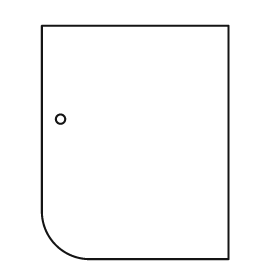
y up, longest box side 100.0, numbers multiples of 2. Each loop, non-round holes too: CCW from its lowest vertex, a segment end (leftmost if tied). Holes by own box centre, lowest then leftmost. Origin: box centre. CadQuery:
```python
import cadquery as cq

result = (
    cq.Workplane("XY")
    .moveTo(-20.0, -50.0)
    .lineTo(40.0, -50.0)
    .lineTo(40.0, 50.0)
    .lineTo(-40.0, 50.0)
    .lineTo(-40.0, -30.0)
    .threePointArc((-34.0, -44.0), (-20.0, -50.0))
    .close()
    .moveTo(-32.0, 10.0)
    .circle(2.0)
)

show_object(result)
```